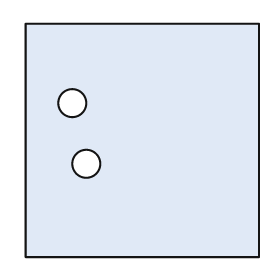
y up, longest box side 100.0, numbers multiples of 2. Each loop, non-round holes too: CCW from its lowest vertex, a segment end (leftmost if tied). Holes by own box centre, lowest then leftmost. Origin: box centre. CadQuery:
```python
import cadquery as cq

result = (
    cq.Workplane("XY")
    .moveTo(-50.0, -50.0)
    .lineTo(50.0, -50.0)
    .lineTo(50.0, 50.0)
    .lineTo(-50.0, 50.0)
    .close()
    .moveTo(-24.0, -10.0)
    .circle(6.0)
    .moveTo(-30.0, 16.0)
    .circle(6.0)
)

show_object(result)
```